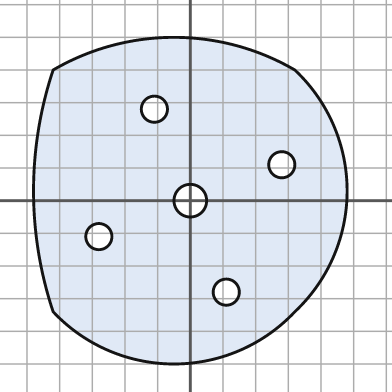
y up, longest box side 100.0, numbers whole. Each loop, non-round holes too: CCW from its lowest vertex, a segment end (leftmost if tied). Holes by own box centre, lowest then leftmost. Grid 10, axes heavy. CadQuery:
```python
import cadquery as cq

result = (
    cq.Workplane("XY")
    .moveTo(-42.0, -34.0)
    .threePointArc((-5.0, -50.0), (32.0, -34.0))
    .threePointArc((48.0, 3.0), (32.0, 40.0))
    .threePointArc((-5.0, 50.0), (-42.0, 40.0))
    .threePointArc((-48.0, 3.0), (-42.0, -34.0))
    .close()
    .moveTo(11.0, -28.0)
    .circle(4.0)
    .moveTo(-28.0, -11.0)
    .circle(4.0)
    .moveTo(0.0, 0.0)
    .circle(5.0)
    .moveTo(28.0, 11.0)
    .circle(4.0)
    .moveTo(-11.0, 28.0)
    .circle(4.0)
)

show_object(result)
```